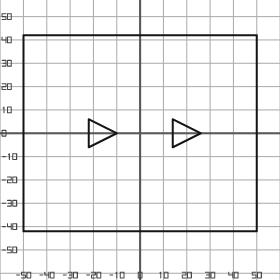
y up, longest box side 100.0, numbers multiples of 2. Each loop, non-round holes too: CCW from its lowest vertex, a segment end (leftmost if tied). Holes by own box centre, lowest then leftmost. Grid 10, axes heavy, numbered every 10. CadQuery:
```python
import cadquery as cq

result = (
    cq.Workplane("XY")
    .moveTo(-50.0, -42.0)
    .lineTo(50.0, -42.0)
    .lineTo(50.0, 42.0)
    .lineTo(-50.0, 42.0)
    .close()
    .moveTo(-22.0, -6.0)
    .lineTo(-10.0, 0.0)
    .lineTo(-22.0, 6.0)
    .close()
    .moveTo(14.0, -6.0)
    .lineTo(26.0, 0.0)
    .lineTo(14.0, 6.0)
    .close()
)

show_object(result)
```